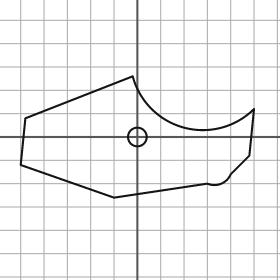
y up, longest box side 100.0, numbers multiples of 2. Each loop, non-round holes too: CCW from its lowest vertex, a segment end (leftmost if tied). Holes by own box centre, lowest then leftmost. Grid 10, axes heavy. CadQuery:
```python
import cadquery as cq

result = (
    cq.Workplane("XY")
    .moveTo(-10.0, -26.0)
    .lineTo(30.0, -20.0)
    .threePointArc((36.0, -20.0), (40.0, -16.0))
    .lineTo(48.0, -8.0)
    .lineTo(50.0, 12.0)
    .threePointArc((20.0, 4.0), (-2.0, 26.0))
    .lineTo(-48.0, 8.0)
    .lineTo(-50.0, -12.0)
    .close()
    .moveTo(0.0, 0.0)
    .circle(4.0)
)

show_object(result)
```